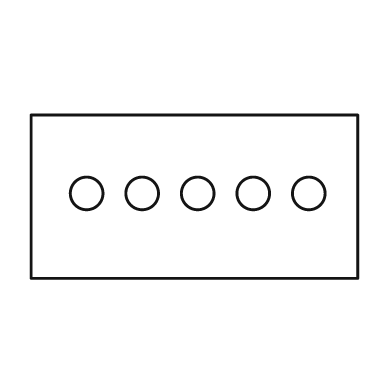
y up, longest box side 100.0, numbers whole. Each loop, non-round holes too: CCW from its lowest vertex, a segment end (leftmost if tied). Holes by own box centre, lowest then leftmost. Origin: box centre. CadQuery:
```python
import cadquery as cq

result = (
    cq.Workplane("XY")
    .moveTo(-50.0, -25.0)
    .lineTo(50.0, -25.0)
    .lineTo(50.0, 25.0)
    .lineTo(-50.0, 25.0)
    .close()
    .moveTo(-33.0, 1.0)
    .circle(5.0)
    .moveTo(-16.0, 1.0)
    .circle(5.0)
    .moveTo(1.0, 1.0)
    .circle(5.0)
    .moveTo(18.0, 1.0)
    .circle(5.0)
    .moveTo(35.0, 1.0)
    .circle(5.0)
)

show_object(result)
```